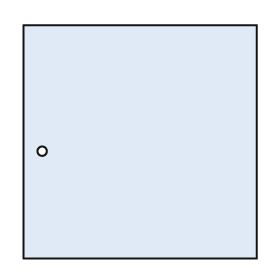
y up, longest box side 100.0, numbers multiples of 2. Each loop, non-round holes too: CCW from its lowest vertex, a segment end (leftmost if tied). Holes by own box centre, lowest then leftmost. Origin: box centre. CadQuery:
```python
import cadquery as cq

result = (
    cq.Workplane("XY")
    .moveTo(-50.0, -50.0)
    .lineTo(50.0, -50.0)
    .lineTo(50.0, 50.0)
    .lineTo(-50.0, 50.0)
    .close()
    .moveTo(-42.0, -4.0)
    .circle(2.0)
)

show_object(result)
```